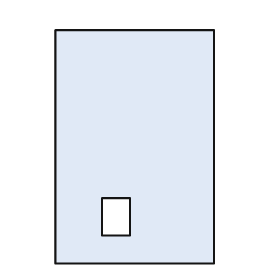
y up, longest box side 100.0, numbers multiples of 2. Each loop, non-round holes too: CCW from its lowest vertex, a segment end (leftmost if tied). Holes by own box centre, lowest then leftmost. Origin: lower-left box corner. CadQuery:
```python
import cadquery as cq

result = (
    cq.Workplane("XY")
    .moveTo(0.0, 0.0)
    .lineTo(68.0, 0.0)
    .lineTo(68.0, 100.0)
    .lineTo(0.0, 100.0)
    .close()
    .moveTo(20.0, 12.0)
    .lineTo(32.0, 12.0)
    .lineTo(32.0, 28.0)
    .lineTo(20.0, 28.0)
    .close()
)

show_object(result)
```